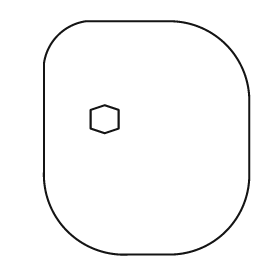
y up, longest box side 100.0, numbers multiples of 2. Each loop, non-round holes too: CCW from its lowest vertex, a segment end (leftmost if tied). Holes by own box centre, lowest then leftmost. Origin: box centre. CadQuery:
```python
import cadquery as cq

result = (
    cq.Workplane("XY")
    .moveTo(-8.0, -50.0)
    .lineTo(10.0, -50.0)
    .threePointArc((34.0, -40.0), (44.0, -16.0))
    .lineTo(44.0, 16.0)
    .threePointArc((34.0, 40.0), (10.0, 50.0))
    .lineTo(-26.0, 50.0)
    .threePointArc((-38.0, 44.0), (-44.0, 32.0))
    .lineTo(-44.0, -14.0)
    .threePointArc((-34.0, -40.0), (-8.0, -50.0))
    .close()
    .moveTo(-18.0, 2.0)
    .lineTo(-12.0, 4.0)
    .lineTo(-12.0, 12.0)
    .lineTo(-18.0, 14.0)
    .lineTo(-24.0, 12.0)
    .lineTo(-24.0, 4.0)
    .close()
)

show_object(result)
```